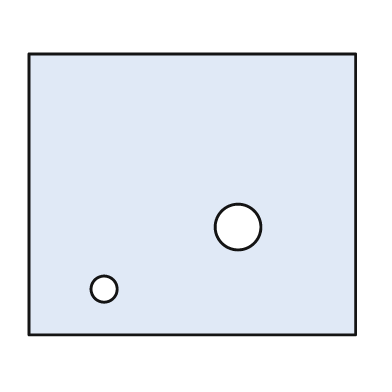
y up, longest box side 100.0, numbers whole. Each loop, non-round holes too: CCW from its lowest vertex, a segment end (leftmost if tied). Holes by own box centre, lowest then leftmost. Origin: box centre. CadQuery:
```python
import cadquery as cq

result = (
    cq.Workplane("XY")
    .moveTo(-50.0, -43.0)
    .lineTo(50.0, -43.0)
    .lineTo(50.0, 43.0)
    .lineTo(-50.0, 43.0)
    .close()
    .moveTo(-27.0, -29.0)
    .circle(4.0)
    .moveTo(14.0, -10.0)
    .circle(7.0)
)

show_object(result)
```